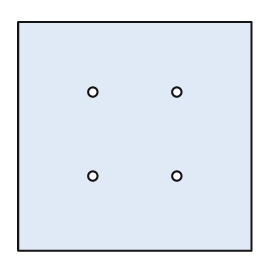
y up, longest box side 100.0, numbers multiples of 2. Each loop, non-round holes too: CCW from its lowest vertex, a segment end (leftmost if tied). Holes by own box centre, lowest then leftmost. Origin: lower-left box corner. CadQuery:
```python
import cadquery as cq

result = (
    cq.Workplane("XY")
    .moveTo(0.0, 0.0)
    .lineTo(100.0, 0.0)
    .lineTo(100.0, 98.0)
    .lineTo(0.0, 98.0)
    .close()
    .moveTo(32.0, 32.0)
    .circle(2.0)
    .moveTo(68.0, 32.0)
    .circle(2.0)
    .moveTo(32.0, 68.0)
    .circle(2.0)
    .moveTo(68.0, 68.0)
    .circle(2.0)
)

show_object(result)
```